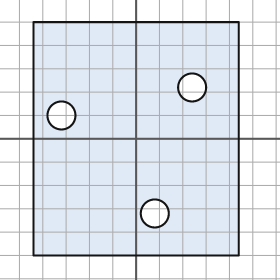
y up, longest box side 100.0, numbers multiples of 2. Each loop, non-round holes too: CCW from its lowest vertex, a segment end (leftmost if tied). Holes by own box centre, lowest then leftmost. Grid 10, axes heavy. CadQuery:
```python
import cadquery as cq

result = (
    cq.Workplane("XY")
    .moveTo(-44.0, -50.0)
    .lineTo(44.0, -50.0)
    .lineTo(44.0, 50.0)
    .lineTo(-44.0, 50.0)
    .close()
    .moveTo(8.0, -32.0)
    .circle(6.0)
    .moveTo(-32.0, 10.0)
    .circle(6.0)
    .moveTo(24.0, 22.0)
    .circle(6.0)
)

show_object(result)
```